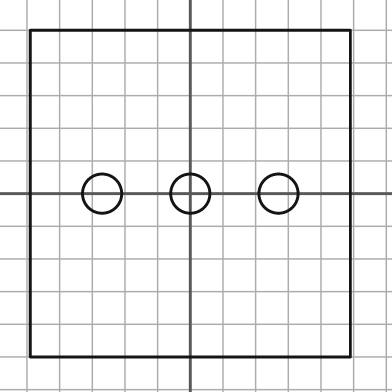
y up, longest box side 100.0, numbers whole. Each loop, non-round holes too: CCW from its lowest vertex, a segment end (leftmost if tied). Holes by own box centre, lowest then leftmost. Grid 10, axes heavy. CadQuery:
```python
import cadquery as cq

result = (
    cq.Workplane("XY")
    .moveTo(-49.0, -50.0)
    .lineTo(49.0, -50.0)
    .lineTo(49.0, 50.0)
    .lineTo(-49.0, 50.0)
    .close()
    .moveTo(-27.0, 0.0)
    .circle(6.0)
    .moveTo(0.0, 0.0)
    .circle(6.0)
    .moveTo(27.0, 0.0)
    .circle(6.0)
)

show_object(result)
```